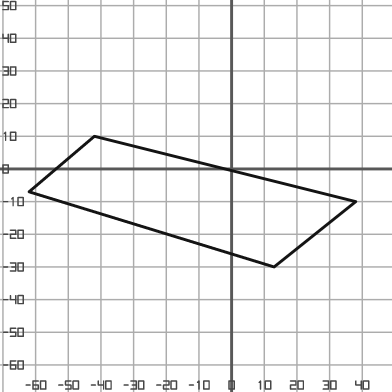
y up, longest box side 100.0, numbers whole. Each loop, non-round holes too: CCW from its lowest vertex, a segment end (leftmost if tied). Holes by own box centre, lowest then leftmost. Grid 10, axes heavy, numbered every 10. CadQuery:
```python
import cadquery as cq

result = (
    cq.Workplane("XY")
    .moveTo(13.0, -30.0)
    .lineTo(38.0, -10.0)
    .lineTo(-42.0, 10.0)
    .lineTo(-62.0, -7.0)
    .close()
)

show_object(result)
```